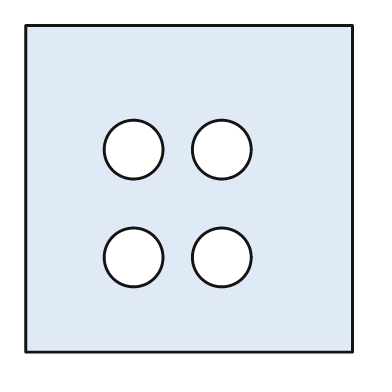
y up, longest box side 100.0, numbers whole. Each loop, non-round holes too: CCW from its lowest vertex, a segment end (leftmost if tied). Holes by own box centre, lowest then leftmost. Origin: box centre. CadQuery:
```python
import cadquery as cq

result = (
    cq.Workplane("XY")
    .moveTo(-50.0, -50.0)
    .lineTo(50.0, -50.0)
    .lineTo(50.0, 50.0)
    .lineTo(-50.0, 50.0)
    .close()
    .moveTo(-17.0, -21.0)
    .circle(9.0)
    .moveTo(10.0, -21.0)
    .circle(9.0)
    .moveTo(-17.0, 12.0)
    .circle(9.0)
    .moveTo(10.0, 12.0)
    .circle(9.0)
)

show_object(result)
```